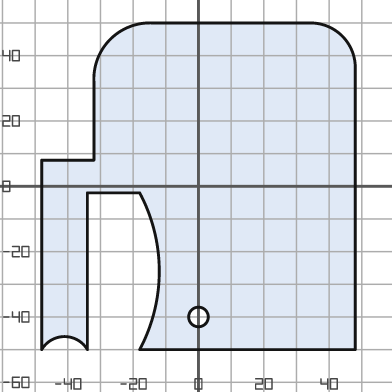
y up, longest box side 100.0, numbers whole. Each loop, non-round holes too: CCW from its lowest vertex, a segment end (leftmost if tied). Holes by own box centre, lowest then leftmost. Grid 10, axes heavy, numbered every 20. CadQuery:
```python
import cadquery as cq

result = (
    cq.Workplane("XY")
    .moveTo(-48.0, -50.0)
    .threePointArc((-41.0, -46.0), (-34.0, -50.0))
    .lineTo(-34.0, -2.0)
    .lineTo(-18.0, -2.0)
    .threePointArc((-12.0, -26.0), (-18.0, -50.0))
    .lineTo(48.0, -50.0)
    .lineTo(48.0, 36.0)
    .threePointArc((44.0, 46.0), (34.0, 50.0))
    .lineTo(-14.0, 50.0)
    .threePointArc((-27.0, 45.0), (-32.0, 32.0))
    .lineTo(-32.0, 8.0)
    .lineTo(-48.0, 8.0)
    .close()
    .moveTo(0.0, -40.0)
    .circle(3.0)
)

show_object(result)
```